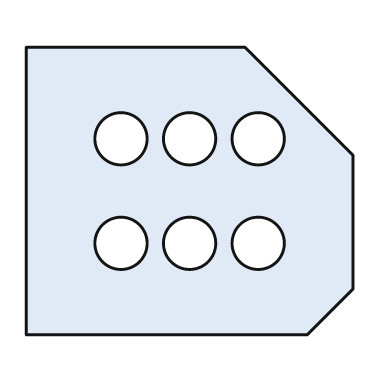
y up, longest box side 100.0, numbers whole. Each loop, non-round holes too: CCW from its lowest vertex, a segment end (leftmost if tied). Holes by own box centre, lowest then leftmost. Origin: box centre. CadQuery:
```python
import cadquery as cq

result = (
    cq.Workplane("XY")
    .moveTo(-50.0, -44.0)
    .lineTo(36.0, -44.0)
    .lineTo(50.0, -30.0)
    .lineTo(50.0, 11.0)
    .lineTo(17.0, 44.0)
    .lineTo(-50.0, 44.0)
    .close()
    .moveTo(-21.0, -16.0)
    .circle(8.0)
    .moveTo(0.0, -16.0)
    .circle(8.0)
    .moveTo(21.0, -16.0)
    .circle(8.0)
    .moveTo(-21.0, 16.0)
    .circle(8.0)
    .moveTo(0.0, 16.0)
    .circle(8.0)
    .moveTo(21.0, 16.0)
    .circle(8.0)
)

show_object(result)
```